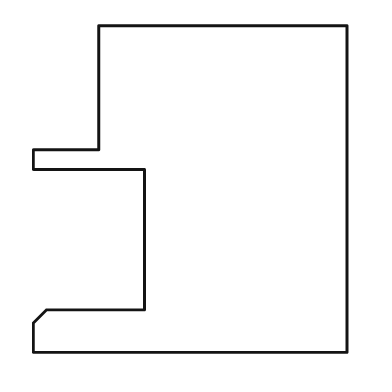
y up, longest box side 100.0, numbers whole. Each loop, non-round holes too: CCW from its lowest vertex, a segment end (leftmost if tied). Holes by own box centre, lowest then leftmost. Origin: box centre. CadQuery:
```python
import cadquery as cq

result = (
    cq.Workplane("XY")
    .moveTo(-48.0, -50.0)
    .lineTo(48.0, -50.0)
    .lineTo(48.0, 50.0)
    .lineTo(-28.0, 50.0)
    .lineTo(-28.0, 12.0)
    .lineTo(-48.0, 12.0)
    .lineTo(-48.0, 6.0)
    .lineTo(-14.0, 6.0)
    .lineTo(-14.0, -37.0)
    .lineTo(-44.0, -37.0)
    .lineTo(-48.0, -41.0)
    .close()
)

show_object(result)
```